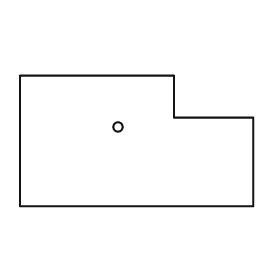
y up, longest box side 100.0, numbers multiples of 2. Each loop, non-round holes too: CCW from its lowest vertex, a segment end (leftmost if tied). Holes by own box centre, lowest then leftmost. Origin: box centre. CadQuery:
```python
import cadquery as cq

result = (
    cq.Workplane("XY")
    .moveTo(-50.0, -28.0)
    .lineTo(50.0, -28.0)
    .lineTo(50.0, 10.0)
    .lineTo(16.0, 10.0)
    .lineTo(16.0, 28.0)
    .lineTo(-50.0, 28.0)
    .close()
    .moveTo(-8.0, 6.0)
    .circle(2.0)
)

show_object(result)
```